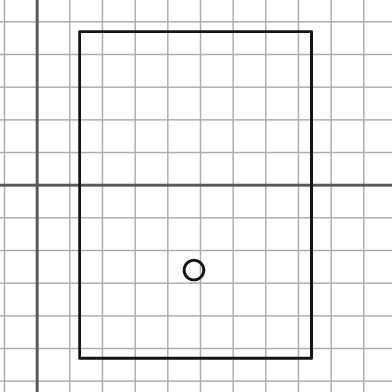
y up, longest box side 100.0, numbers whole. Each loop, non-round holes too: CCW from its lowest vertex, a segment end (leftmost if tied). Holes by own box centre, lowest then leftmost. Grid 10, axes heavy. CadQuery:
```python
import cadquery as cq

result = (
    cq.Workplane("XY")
    .moveTo(13.0, -53.0)
    .lineTo(84.0, -53.0)
    .lineTo(84.0, 47.0)
    .lineTo(13.0, 47.0)
    .close()
    .moveTo(48.0, -26.0)
    .circle(3.0)
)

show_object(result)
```